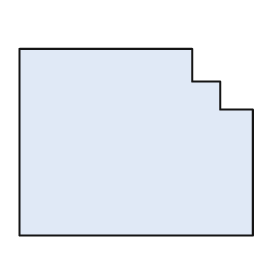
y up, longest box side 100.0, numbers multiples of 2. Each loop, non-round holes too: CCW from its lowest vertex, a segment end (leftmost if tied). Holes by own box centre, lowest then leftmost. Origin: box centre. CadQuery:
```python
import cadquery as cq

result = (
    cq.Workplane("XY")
    .moveTo(-50.0, -40.0)
    .lineTo(50.0, -40.0)
    .lineTo(50.0, 14.0)
    .lineTo(36.0, 14.0)
    .lineTo(36.0, 26.0)
    .lineTo(24.0, 26.0)
    .lineTo(24.0, 40.0)
    .lineTo(-50.0, 40.0)
    .close()
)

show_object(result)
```